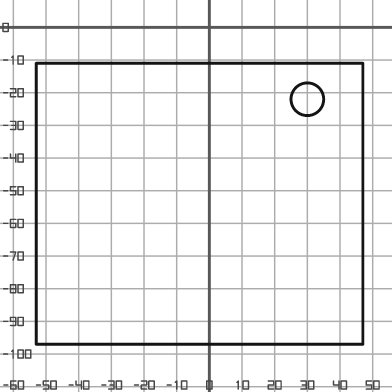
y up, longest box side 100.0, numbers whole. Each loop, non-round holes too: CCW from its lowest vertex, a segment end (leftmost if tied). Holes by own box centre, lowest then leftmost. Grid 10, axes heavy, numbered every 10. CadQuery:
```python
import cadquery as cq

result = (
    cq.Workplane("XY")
    .moveTo(-53.0, -97.0)
    .lineTo(47.0, -97.0)
    .lineTo(47.0, -11.0)
    .lineTo(-53.0, -11.0)
    .close()
    .moveTo(30.0, -22.0)
    .circle(5.0)
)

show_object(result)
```